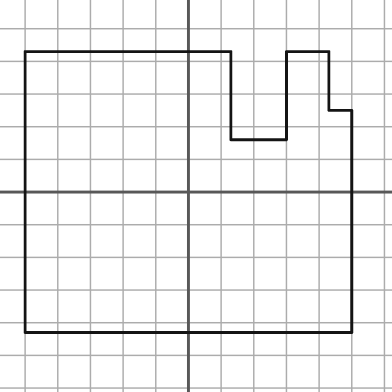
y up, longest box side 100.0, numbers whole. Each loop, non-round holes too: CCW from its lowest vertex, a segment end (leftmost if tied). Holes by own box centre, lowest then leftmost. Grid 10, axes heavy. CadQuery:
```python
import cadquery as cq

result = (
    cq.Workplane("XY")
    .moveTo(-50.0, -43.0)
    .lineTo(50.0, -43.0)
    .lineTo(50.0, 25.0)
    .lineTo(43.0, 25.0)
    .lineTo(43.0, 43.0)
    .lineTo(30.0, 43.0)
    .lineTo(30.0, 16.0)
    .lineTo(13.0, 16.0)
    .lineTo(13.0, 43.0)
    .lineTo(-50.0, 43.0)
    .close()
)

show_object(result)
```